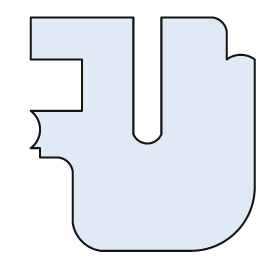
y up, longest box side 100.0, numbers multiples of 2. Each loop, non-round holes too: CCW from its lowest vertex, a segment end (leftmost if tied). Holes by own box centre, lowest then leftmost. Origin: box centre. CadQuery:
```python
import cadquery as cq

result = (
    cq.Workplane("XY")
    .moveTo(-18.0, -50.0)
    .lineTo(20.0, -50.0)
    .threePointArc((40.0, -42.0), (48.0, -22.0))
    .lineTo(48.0, 32.0)
    .threePointArc((42.0, 34.0), (36.0, 32.0))
    .lineTo(36.0, 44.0)
    .threePointArc((34.0, 48.0), (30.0, 50.0))
    .lineTo(8.0, 50.0)
    .lineTo(8.0, 0.0)
    .threePointArc((2.0, -4.0), (-4.0, 0.0))
    .lineTo(-4.0, 50.0)
    .lineTo(-48.0, 50.0)
    .lineTo(-48.0, 32.0)
    .lineTo(-26.0, 32.0)
    .lineTo(-26.0, 10.0)
    .lineTo(-48.0, 10.0)
    .threePointArc((-44.0, 2.0), (-48.0, -6.0))
    .lineTo(-44.0, -6.0)
    .lineTo(-44.0, -10.0)
    .lineTo(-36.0, -10.0)
    .threePointArc((-32.0, -12.0), (-30.0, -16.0))
    .lineTo(-30.0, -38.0)
    .threePointArc((-26.0, -46.0), (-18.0, -50.0))
    .close()
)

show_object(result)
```